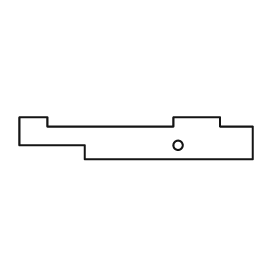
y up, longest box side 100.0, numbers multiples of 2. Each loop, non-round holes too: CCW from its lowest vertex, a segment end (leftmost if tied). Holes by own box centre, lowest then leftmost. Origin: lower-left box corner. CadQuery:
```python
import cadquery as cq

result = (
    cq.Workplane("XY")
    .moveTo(28.0, 0.0)
    .lineTo(100.0, 0.0)
    .lineTo(100.0, 14.0)
    .lineTo(86.0, 14.0)
    .lineTo(86.0, 18.0)
    .lineTo(66.0, 18.0)
    .lineTo(66.0, 14.0)
    .lineTo(12.0, 14.0)
    .lineTo(12.0, 18.0)
    .lineTo(0.0, 18.0)
    .lineTo(0.0, 6.0)
    .lineTo(28.0, 6.0)
    .close()
    .moveTo(68.0, 6.0)
    .circle(2.0)
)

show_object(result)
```